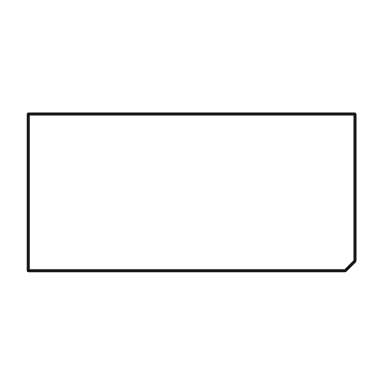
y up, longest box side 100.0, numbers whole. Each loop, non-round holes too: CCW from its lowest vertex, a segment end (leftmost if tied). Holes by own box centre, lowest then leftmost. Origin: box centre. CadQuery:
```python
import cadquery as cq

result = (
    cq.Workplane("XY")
    .moveTo(-50.0, -24.0)
    .lineTo(47.0, -24.0)
    .lineTo(50.0, -21.0)
    .lineTo(50.0, 24.0)
    .lineTo(-50.0, 24.0)
    .close()
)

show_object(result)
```